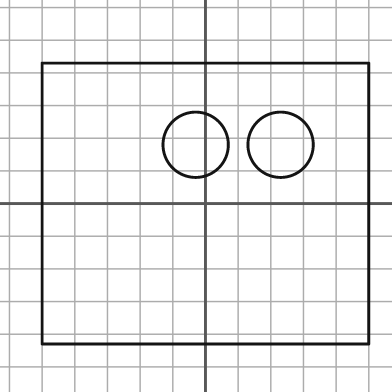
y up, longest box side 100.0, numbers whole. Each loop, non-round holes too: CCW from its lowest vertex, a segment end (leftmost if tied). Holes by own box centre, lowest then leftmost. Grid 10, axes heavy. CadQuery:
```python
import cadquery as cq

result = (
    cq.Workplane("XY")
    .moveTo(-50.0, -43.0)
    .lineTo(50.0, -43.0)
    .lineTo(50.0, 43.0)
    .lineTo(-50.0, 43.0)
    .close()
    .moveTo(-3.0, 18.0)
    .circle(10.0)
    .moveTo(23.0, 18.0)
    .circle(10.0)
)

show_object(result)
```